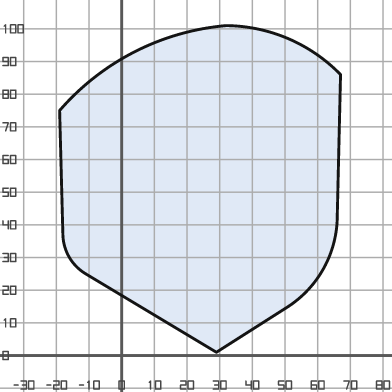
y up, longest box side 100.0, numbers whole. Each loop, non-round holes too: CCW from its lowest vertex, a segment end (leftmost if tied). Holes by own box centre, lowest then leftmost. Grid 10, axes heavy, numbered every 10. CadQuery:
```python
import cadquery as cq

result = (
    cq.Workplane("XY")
    .moveTo(29.0, 1.0)
    .lineTo(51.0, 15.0)
    .threePointArc((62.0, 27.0), (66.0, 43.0))
    .lineTo(67.0, 86.0)
    .threePointArc((51.0, 97.0), (32.0, 101.0))
    .threePointArc((4.0, 93.0), (-19.0, 75.0))
    .lineTo(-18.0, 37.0)
    .threePointArc((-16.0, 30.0), (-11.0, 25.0))
    .close()
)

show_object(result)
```